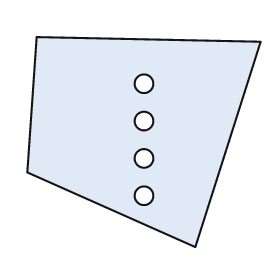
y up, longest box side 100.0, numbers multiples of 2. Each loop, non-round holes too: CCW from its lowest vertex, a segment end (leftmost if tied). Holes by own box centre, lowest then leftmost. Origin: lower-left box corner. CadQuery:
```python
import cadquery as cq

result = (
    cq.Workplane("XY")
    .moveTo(72.0, 0.0)
    .lineTo(100.0, 88.0)
    .lineTo(4.0, 90.0)
    .lineTo(0.0, 32.0)
    .close()
    .moveTo(50.0, 22.0)
    .circle(4.0)
    .moveTo(50.0, 38.0)
    .circle(4.0)
    .moveTo(50.0, 54.0)
    .circle(4.0)
    .moveTo(50.0, 70.0)
    .circle(4.0)
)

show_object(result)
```